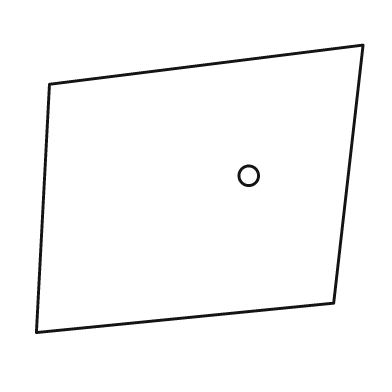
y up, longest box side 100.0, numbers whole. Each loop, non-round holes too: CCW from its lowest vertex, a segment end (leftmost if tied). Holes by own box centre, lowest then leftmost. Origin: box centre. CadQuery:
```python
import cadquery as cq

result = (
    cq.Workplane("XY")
    .moveTo(-50.0, -44.0)
    .lineTo(41.0, -35.0)
    .lineTo(50.0, 44.0)
    .lineTo(-46.0, 32.0)
    .close()
    .moveTo(15.0, 4.0)
    .circle(3.0)
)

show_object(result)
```